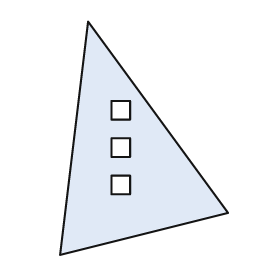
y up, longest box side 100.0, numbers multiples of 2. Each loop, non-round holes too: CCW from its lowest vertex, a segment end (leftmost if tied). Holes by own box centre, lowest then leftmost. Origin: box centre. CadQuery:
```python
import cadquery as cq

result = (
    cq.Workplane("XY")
    .moveTo(-36.0, -50.0)
    .lineTo(36.0, -32.0)
    .lineTo(-24.0, 50.0)
    .close()
    .moveTo(-14.0, -24.0)
    .lineTo(-6.0, -24.0)
    .lineTo(-6.0, -16.0)
    .lineTo(-14.0, -16.0)
    .close()
    .moveTo(-14.0, -8.0)
    .lineTo(-6.0, -8.0)
    .lineTo(-6.0, 0.0)
    .lineTo(-14.0, 0.0)
    .close()
    .moveTo(-14.0, 8.0)
    .lineTo(-6.0, 8.0)
    .lineTo(-6.0, 16.0)
    .lineTo(-14.0, 16.0)
    .close()
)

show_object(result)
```